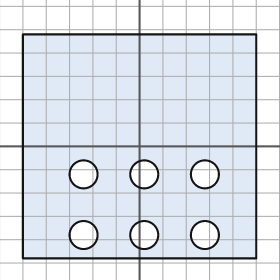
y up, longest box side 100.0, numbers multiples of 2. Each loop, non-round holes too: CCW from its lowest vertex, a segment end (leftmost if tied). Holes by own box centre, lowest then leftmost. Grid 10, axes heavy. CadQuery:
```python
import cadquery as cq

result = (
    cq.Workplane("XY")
    .moveTo(-50.0, -48.0)
    .lineTo(50.0, -48.0)
    .lineTo(50.0, 48.0)
    .lineTo(-50.0, 48.0)
    .close()
    .moveTo(-24.0, -38.0)
    .circle(6.0)
    .moveTo(2.0, -38.0)
    .circle(6.0)
    .moveTo(28.0, -38.0)
    .circle(6.0)
    .moveTo(-24.0, -12.0)
    .circle(6.0)
    .moveTo(2.0, -12.0)
    .circle(6.0)
    .moveTo(28.0, -12.0)
    .circle(6.0)
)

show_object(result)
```